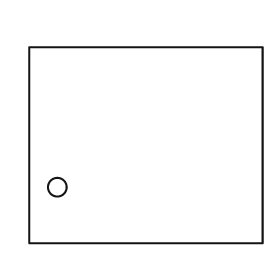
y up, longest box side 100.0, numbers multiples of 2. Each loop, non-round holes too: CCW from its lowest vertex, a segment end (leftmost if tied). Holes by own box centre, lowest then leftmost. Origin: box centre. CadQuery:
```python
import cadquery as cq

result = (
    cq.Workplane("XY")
    .moveTo(-50.0, -42.0)
    .lineTo(50.0, -42.0)
    .lineTo(50.0, 42.0)
    .lineTo(-50.0, 42.0)
    .close()
    .moveTo(-38.0, -18.0)
    .circle(4.0)
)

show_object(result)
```